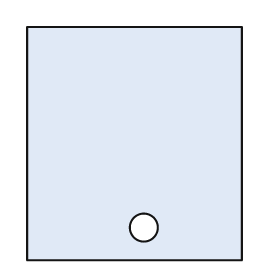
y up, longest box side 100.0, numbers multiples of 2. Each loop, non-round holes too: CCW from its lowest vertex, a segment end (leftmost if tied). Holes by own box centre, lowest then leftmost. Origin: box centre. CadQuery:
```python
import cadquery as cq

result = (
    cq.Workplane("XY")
    .moveTo(-46.0, -50.0)
    .lineTo(46.0, -50.0)
    .lineTo(46.0, 50.0)
    .lineTo(-46.0, 50.0)
    .close()
    .moveTo(4.0, -36.0)
    .circle(6.0)
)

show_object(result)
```